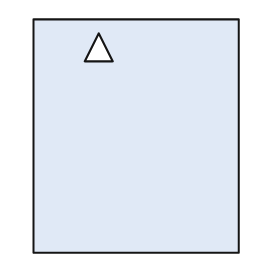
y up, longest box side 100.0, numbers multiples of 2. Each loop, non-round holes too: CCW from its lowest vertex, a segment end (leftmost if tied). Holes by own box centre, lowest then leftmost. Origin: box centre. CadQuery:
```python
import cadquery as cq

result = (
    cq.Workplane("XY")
    .moveTo(-44.0, -50.0)
    .lineTo(44.0, -50.0)
    .lineTo(44.0, 50.0)
    .lineTo(-44.0, 50.0)
    .close()
    .moveTo(-22.0, 32.0)
    .lineTo(-10.0, 32.0)
    .lineTo(-16.0, 44.0)
    .close()
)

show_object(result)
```